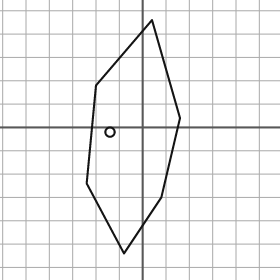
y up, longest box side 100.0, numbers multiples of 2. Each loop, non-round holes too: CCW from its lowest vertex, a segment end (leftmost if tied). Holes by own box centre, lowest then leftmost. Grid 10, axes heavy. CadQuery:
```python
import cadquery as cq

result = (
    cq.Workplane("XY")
    .moveTo(-8.0, -54.0)
    .lineTo(8.0, -30.0)
    .lineTo(16.0, 4.0)
    .lineTo(4.0, 46.0)
    .lineTo(-20.0, 18.0)
    .lineTo(-24.0, -24.0)
    .close()
    .moveTo(-14.0, -2.0)
    .circle(2.0)
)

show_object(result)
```